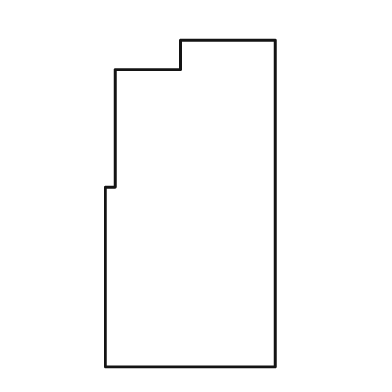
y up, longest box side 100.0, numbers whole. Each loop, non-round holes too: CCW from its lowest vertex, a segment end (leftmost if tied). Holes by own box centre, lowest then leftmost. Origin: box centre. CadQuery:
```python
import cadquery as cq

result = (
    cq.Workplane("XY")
    .moveTo(-26.0, -50.0)
    .lineTo(26.0, -50.0)
    .lineTo(26.0, 50.0)
    .lineTo(-3.0, 50.0)
    .lineTo(-3.0, 41.0)
    .lineTo(-23.0, 41.0)
    .lineTo(-23.0, 5.0)
    .lineTo(-26.0, 5.0)
    .close()
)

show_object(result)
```